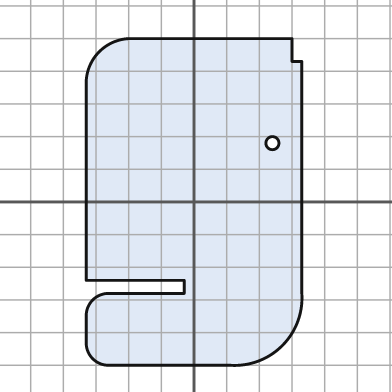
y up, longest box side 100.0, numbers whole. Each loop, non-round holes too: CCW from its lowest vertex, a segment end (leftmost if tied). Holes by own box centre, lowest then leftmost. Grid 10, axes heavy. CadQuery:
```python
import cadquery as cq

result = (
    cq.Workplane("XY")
    .moveTo(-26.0, -50.0)
    .lineTo(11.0, -50.0)
    .threePointArc((27.0, -44.0), (33.0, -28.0))
    .lineTo(33.0, 43.0)
    .lineTo(30.0, 43.0)
    .lineTo(30.0, 50.0)
    .lineTo(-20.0, 50.0)
    .threePointArc((-29.0, 46.0), (-33.0, 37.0))
    .lineTo(-33.0, -24.0)
    .lineTo(-3.0, -24.0)
    .lineTo(-3.0, -28.0)
    .lineTo(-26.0, -28.0)
    .threePointArc((-31.0, -30.0), (-33.0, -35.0))
    .lineTo(-33.0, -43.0)
    .threePointArc((-31.0, -48.0), (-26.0, -50.0))
    .close()
    .moveTo(24.0, 18.0)
    .circle(2.0)
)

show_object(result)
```